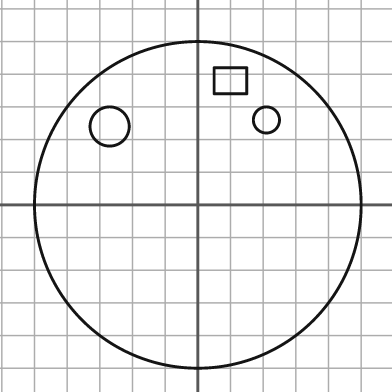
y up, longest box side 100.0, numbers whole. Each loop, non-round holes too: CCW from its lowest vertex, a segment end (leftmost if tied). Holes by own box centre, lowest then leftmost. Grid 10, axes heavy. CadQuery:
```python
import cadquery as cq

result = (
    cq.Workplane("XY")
    .moveTo(0.0, 0.0)
    .circle(50.0)
    .moveTo(-27.0, 24.0)
    .circle(6.0)
    .moveTo(21.0, 26.0)
    .circle(4.0)
    .moveTo(5.0, 34.0)
    .lineTo(15.0, 34.0)
    .lineTo(15.0, 42.0)
    .lineTo(5.0, 42.0)
    .close()
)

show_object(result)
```